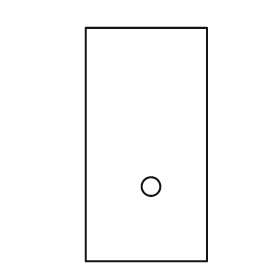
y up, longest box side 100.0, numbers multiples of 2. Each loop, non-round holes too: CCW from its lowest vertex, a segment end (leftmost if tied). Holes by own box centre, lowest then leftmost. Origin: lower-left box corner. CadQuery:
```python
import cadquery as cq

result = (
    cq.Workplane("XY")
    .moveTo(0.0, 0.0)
    .lineTo(52.0, 0.0)
    .lineTo(52.0, 100.0)
    .lineTo(0.0, 100.0)
    .close()
    .moveTo(28.0, 32.0)
    .circle(4.0)
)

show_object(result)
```